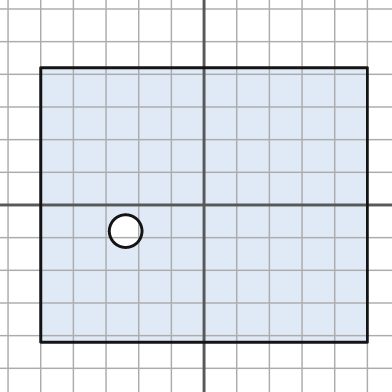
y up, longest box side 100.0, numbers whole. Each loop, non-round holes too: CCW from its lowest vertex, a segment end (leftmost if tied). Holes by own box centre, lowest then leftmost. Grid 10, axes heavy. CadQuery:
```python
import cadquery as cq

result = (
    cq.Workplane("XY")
    .moveTo(-50.0, -42.0)
    .lineTo(50.0, -42.0)
    .lineTo(50.0, 42.0)
    .lineTo(-50.0, 42.0)
    .close()
    .moveTo(-24.0, -8.0)
    .circle(5.0)
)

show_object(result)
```